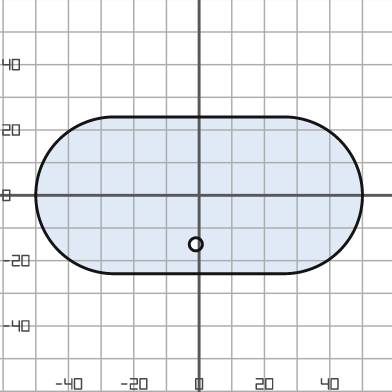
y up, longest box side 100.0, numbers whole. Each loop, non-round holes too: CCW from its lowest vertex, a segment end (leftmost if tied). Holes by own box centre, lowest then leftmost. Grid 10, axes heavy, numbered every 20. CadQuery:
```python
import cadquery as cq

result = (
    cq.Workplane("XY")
    .moveTo(-26.0, -24.0)
    .lineTo(26.0, -24.0)
    .threePointArc((50.0, 0.0), (26.0, 24.0))
    .lineTo(-26.0, 24.0)
    .threePointArc((-50.0, 0.0), (-26.0, -24.0))
    .close()
    .moveTo(-1.0, -15.0)
    .circle(2.0)
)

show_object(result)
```